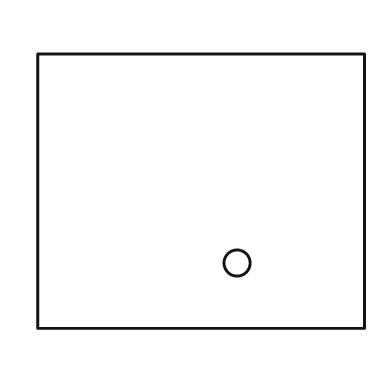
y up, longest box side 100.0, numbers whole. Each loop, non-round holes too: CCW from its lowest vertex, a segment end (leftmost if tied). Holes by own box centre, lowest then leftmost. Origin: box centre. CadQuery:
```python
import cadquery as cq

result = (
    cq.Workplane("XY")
    .moveTo(-50.0, -42.0)
    .lineTo(50.0, -42.0)
    .lineTo(50.0, 42.0)
    .lineTo(-50.0, 42.0)
    .close()
    .moveTo(11.0, -22.0)
    .circle(4.0)
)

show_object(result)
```